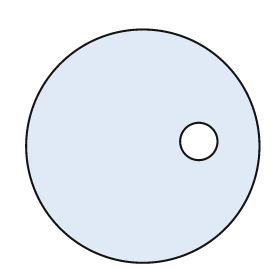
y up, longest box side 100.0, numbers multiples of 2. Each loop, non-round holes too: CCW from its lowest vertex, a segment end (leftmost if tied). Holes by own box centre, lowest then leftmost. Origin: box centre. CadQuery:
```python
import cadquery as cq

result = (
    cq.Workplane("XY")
    .moveTo(0.0, 0.0)
    .circle(50.0)
    .moveTo(24.0, 2.0)
    .circle(8.0)
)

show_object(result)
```